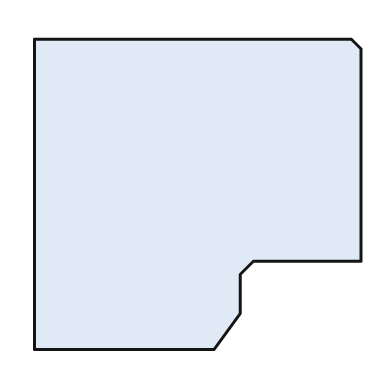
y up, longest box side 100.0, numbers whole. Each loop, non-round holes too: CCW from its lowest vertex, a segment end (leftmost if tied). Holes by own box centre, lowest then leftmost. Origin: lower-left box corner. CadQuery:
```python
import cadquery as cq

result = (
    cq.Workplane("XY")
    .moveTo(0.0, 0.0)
    .lineTo(55.0, 0.0)
    .lineTo(63.0, 11.0)
    .lineTo(63.0, 23.0)
    .lineTo(67.0, 27.0)
    .lineTo(100.0, 27.0)
    .lineTo(100.0, 92.0)
    .lineTo(97.0, 95.0)
    .lineTo(0.0, 95.0)
    .close()
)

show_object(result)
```